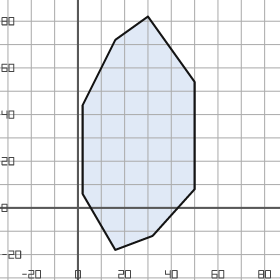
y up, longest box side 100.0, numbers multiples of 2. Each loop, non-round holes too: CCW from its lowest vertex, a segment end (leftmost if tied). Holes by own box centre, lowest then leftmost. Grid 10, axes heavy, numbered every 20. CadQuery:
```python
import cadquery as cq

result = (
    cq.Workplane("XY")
    .moveTo(16.0, -18.0)
    .lineTo(32.0, -12.0)
    .lineTo(50.0, 8.0)
    .lineTo(50.0, 54.0)
    .lineTo(30.0, 82.0)
    .lineTo(16.0, 72.0)
    .lineTo(2.0, 44.0)
    .lineTo(2.0, 6.0)
    .close()
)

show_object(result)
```